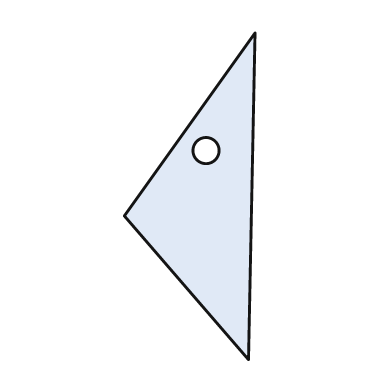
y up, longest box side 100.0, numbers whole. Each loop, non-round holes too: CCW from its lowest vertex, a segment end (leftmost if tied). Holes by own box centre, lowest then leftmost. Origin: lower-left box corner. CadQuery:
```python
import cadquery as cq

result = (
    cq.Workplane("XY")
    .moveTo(38.0, 0.0)
    .lineTo(40.0, 100.0)
    .lineTo(0.0, 44.0)
    .close()
    .moveTo(25.0, 64.0)
    .circle(4.0)
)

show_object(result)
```